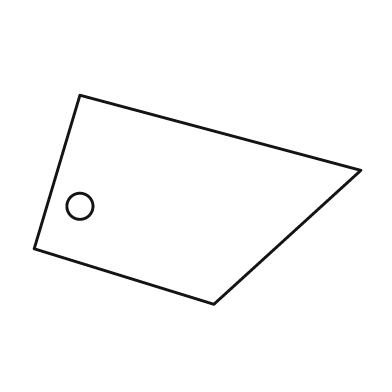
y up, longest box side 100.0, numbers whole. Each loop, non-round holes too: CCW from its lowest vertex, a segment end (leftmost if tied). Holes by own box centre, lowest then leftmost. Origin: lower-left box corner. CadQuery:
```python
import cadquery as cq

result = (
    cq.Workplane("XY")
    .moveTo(55.0, 0.0)
    .lineTo(100.0, 41.0)
    .lineTo(14.0, 64.0)
    .lineTo(0.0, 17.0)
    .close()
    .moveTo(14.0, 30.0)
    .circle(4.0)
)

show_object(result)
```